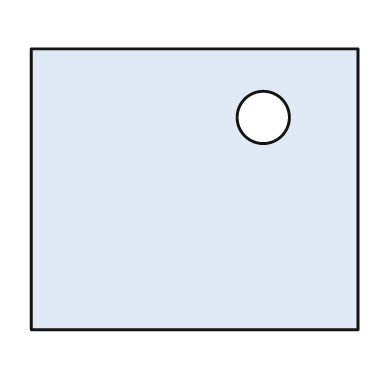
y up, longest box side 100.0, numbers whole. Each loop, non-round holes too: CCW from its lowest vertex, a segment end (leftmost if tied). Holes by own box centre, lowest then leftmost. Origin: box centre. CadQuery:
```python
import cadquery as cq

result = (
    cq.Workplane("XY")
    .moveTo(-50.0, -43.0)
    .lineTo(50.0, -43.0)
    .lineTo(50.0, 43.0)
    .lineTo(-50.0, 43.0)
    .close()
    .moveTo(21.0, 22.0)
    .circle(8.0)
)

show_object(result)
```